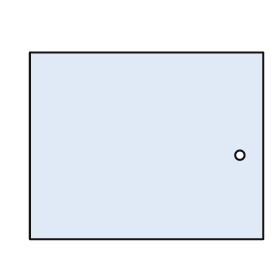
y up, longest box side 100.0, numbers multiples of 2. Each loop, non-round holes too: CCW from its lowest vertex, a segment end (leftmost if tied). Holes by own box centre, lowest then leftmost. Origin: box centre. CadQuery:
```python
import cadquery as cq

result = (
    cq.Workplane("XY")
    .moveTo(-50.0, -40.0)
    .lineTo(50.0, -40.0)
    .lineTo(50.0, 40.0)
    .lineTo(-50.0, 40.0)
    .close()
    .moveTo(40.0, -4.0)
    .circle(2.0)
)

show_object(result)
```